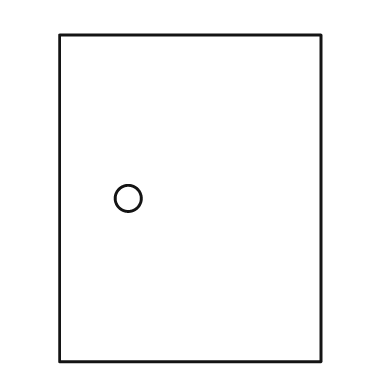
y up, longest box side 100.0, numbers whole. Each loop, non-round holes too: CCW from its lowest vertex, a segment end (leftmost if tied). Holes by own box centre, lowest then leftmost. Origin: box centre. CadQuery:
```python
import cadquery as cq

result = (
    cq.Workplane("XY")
    .moveTo(-40.0, -50.0)
    .lineTo(40.0, -50.0)
    .lineTo(40.0, 50.0)
    .lineTo(-40.0, 50.0)
    .close()
    .moveTo(-19.0, 0.0)
    .circle(4.0)
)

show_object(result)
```